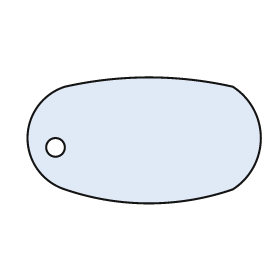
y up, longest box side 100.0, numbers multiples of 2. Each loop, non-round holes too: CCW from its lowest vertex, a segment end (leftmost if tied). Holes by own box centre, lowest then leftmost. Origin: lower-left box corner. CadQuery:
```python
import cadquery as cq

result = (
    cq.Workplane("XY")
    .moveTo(16.0, 6.0)
    .threePointArc((52.0, 0.0), (88.0, 6.0))
    .threePointArc((100.0, 28.0), (88.0, 50.0))
    .threePointArc((52.0, 54.0), (16.0, 50.0))
    .threePointArc((0.0, 28.0), (16.0, 6.0))
    .close()
    .moveTo(12.0, 24.0)
    .circle(4.0)
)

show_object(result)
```